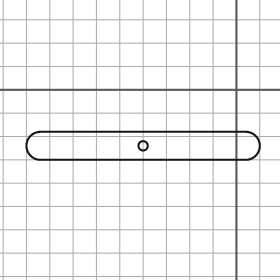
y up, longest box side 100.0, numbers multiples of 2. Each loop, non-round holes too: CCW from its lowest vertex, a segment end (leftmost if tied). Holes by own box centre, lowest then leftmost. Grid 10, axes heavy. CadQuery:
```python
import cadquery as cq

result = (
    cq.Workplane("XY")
    .moveTo(-84.0, -30.0)
    .lineTo(4.0, -30.0)
    .threePointArc((10.0, -24.0), (4.0, -18.0))
    .lineTo(-84.0, -18.0)
    .threePointArc((-90.0, -24.0), (-84.0, -30.0))
    .close()
    .moveTo(-40.0, -24.0)
    .circle(2.0)
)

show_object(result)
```